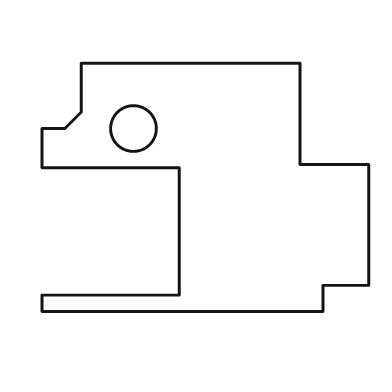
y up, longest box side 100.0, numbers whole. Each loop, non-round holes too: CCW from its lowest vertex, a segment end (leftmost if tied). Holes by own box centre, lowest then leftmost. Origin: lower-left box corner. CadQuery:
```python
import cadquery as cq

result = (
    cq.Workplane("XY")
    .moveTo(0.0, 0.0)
    .lineTo(86.0, 0.0)
    .lineTo(86.0, 8.0)
    .lineTo(100.0, 8.0)
    .lineTo(100.0, 45.0)
    .lineTo(79.0, 45.0)
    .lineTo(79.0, 76.0)
    .lineTo(12.0, 76.0)
    .lineTo(12.0, 61.0)
    .lineTo(7.0, 56.0)
    .lineTo(0.0, 56.0)
    .lineTo(0.0, 44.0)
    .lineTo(42.0, 44.0)
    .lineTo(42.0, 5.0)
    .lineTo(0.0, 5.0)
    .close()
    .moveTo(28.0, 56.0)
    .circle(7.0)
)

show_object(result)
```